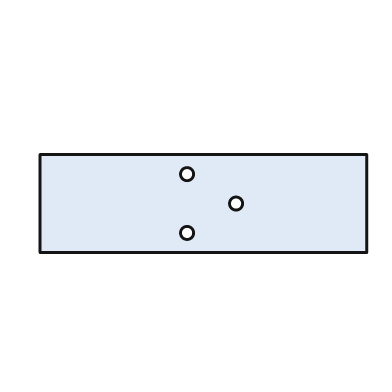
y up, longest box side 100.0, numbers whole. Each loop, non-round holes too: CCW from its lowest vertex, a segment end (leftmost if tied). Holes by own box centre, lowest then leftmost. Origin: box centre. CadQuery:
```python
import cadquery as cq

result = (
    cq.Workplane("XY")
    .moveTo(-50.0, -15.0)
    .lineTo(50.0, -15.0)
    .lineTo(50.0, 15.0)
    .lineTo(-50.0, 15.0)
    .close()
    .moveTo(-5.0, -9.0)
    .circle(2.0)
    .moveTo(10.0, 0.0)
    .circle(2.0)
    .moveTo(-5.0, 9.0)
    .circle(2.0)
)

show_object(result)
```